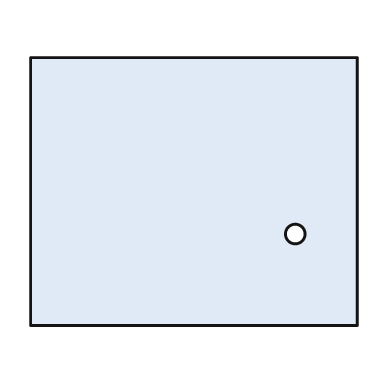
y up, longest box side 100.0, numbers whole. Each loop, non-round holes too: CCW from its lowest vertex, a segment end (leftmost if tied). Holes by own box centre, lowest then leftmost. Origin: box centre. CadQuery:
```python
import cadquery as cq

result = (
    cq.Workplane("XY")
    .moveTo(-50.0, -41.0)
    .lineTo(50.0, -41.0)
    .lineTo(50.0, 41.0)
    .lineTo(-50.0, 41.0)
    .close()
    .moveTo(31.0, -13.0)
    .circle(3.0)
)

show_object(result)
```